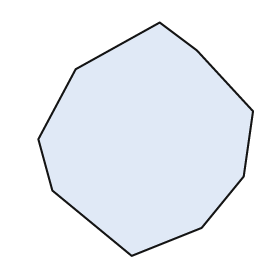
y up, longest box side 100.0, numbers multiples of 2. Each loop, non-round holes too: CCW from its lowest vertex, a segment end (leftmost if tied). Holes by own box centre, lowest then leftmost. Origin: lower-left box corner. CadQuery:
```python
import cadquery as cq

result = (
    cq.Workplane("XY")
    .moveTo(40.0, 0.0)
    .lineTo(70.0, 12.0)
    .lineTo(88.0, 34.0)
    .lineTo(92.0, 62.0)
    .lineTo(68.0, 88.0)
    .lineTo(52.0, 100.0)
    .lineTo(16.0, 80.0)
    .lineTo(0.0, 50.0)
    .lineTo(6.0, 28.0)
    .close()
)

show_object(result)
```